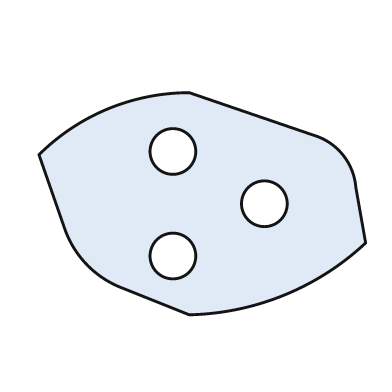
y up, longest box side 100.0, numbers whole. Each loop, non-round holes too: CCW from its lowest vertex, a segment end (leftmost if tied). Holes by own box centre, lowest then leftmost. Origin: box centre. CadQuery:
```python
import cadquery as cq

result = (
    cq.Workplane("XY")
    .moveTo(-4.0, -34.0)
    .threePointArc((25.0, -28.0), (50.0, -12.0))
    .lineTo(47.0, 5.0)
    .threePointArc((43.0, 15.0), (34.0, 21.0))
    .lineTo(-4.0, 34.0)
    .threePointArc((-29.0, 29.0), (-50.0, 15.0))
    .lineTo(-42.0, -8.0)
    .threePointArc((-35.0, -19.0), (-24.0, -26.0))
    .close()
    .moveTo(-9.0, -16.0)
    .circle(7.0)
    .moveTo(19.0, 0.0)
    .circle(7.0)
    .moveTo(-9.0, 16.0)
    .circle(7.0)
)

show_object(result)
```